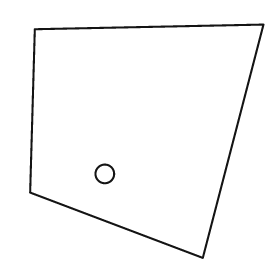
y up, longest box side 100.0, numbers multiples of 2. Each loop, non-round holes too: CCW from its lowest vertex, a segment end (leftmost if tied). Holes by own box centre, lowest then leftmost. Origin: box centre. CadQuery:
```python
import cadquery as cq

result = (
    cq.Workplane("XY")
    .moveTo(24.0, -50.0)
    .lineTo(50.0, 50.0)
    .lineTo(-48.0, 48.0)
    .lineTo(-50.0, -22.0)
    .close()
    .moveTo(-18.0, -14.0)
    .circle(4.0)
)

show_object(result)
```